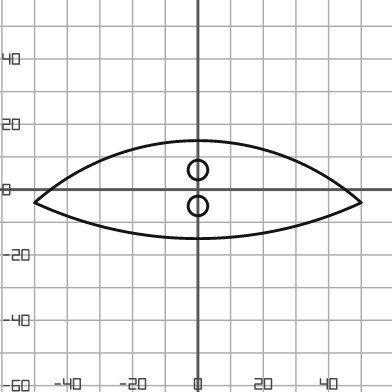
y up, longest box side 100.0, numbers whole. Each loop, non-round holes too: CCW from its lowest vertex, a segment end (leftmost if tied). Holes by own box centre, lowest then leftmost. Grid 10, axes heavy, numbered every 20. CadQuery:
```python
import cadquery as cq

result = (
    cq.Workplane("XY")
    .moveTo(-50.0, -4.0)
    .threePointArc((0.0, -15.0), (50.0, -4.0))
    .threePointArc((0.0, 15.0), (-50.0, -4.0))
    .close()
    .moveTo(0.0, -5.0)
    .circle(3.0)
    .moveTo(0.0, 6.0)
    .circle(3.0)
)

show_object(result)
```